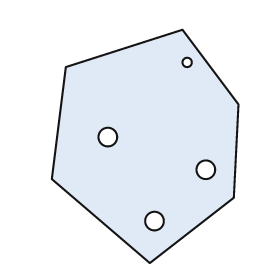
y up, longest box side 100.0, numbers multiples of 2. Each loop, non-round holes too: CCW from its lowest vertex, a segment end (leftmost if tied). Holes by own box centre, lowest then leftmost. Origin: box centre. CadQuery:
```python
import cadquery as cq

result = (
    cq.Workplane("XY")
    .moveTo(2.0, -50.0)
    .lineTo(38.0, -22.0)
    .lineTo(40.0, 18.0)
    .lineTo(16.0, 50.0)
    .lineTo(-34.0, 34.0)
    .lineTo(-40.0, -14.0)
    .close()
    .moveTo(4.0, -32.0)
    .circle(4.0)
    .moveTo(26.0, -10.0)
    .circle(4.0)
    .moveTo(-16.0, 4.0)
    .circle(4.0)
    .moveTo(18.0, 36.0)
    .circle(2.0)
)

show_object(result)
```